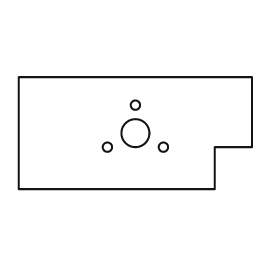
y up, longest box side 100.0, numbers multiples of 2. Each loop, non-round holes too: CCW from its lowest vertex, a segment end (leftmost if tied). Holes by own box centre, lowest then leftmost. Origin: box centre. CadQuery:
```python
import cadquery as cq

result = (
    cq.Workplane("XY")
    .moveTo(-50.0, -24.0)
    .lineTo(34.0, -24.0)
    .lineTo(34.0, -6.0)
    .lineTo(50.0, -6.0)
    .lineTo(50.0, 24.0)
    .lineTo(-50.0, 24.0)
    .close()
    .moveTo(-12.0, -6.0)
    .circle(2.0)
    .moveTo(12.0, -6.0)
    .circle(2.0)
    .moveTo(0.0, 0.0)
    .circle(6.0)
    .moveTo(0.0, 12.0)
    .circle(2.0)
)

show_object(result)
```